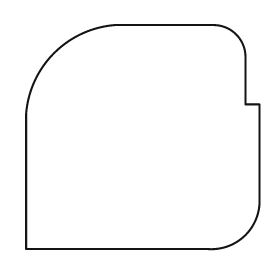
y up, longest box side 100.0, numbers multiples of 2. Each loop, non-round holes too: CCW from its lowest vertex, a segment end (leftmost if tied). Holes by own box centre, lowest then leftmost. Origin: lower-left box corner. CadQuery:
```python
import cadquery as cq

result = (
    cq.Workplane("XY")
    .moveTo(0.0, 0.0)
    .lineTo(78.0, 0.0)
    .threePointArc((94.0, 6.0), (100.0, 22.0))
    .lineTo(100.0, 62.0)
    .lineTo(94.0, 62.0)
    .lineTo(94.0, 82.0)
    .threePointArc((90.0, 92.0), (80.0, 96.0))
    .lineTo(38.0, 96.0)
    .threePointArc((12.0, 84.0), (0.0, 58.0))
    .close()
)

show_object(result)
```